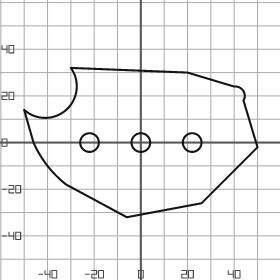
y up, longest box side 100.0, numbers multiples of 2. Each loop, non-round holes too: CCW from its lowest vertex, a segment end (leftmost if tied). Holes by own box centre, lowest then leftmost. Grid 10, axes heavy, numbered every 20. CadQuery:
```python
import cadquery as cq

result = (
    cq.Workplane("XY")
    .moveTo(-6.0, -32.0)
    .lineTo(26.0, -26.0)
    .lineTo(50.0, -2.0)
    .lineTo(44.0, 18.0)
    .threePointArc((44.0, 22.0), (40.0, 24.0))
    .lineTo(20.0, 30.0)
    .lineTo(-30.0, 32.0)
    .threePointArc((-32.0, 14.0), (-50.0, 14.0))
    .lineTo(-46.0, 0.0)
    .threePointArc((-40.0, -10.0), (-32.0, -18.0))
    .close()
    .moveTo(-22.0, 0.0)
    .circle(4.0)
    .moveTo(0.0, 0.0)
    .circle(4.0)
    .moveTo(22.0, 0.0)
    .circle(4.0)
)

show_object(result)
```